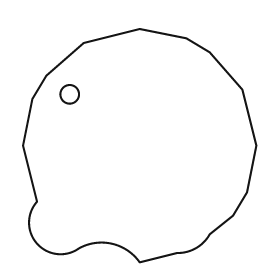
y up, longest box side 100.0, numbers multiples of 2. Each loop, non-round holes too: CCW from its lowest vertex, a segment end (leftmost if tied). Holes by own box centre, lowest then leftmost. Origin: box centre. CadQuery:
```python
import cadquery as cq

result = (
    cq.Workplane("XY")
    .moveTo(0.0, -50.0)
    .lineTo(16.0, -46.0)
    .threePointArc((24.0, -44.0), (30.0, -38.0))
    .lineTo(40.0, -30.0)
    .lineTo(46.0, -20.0)
    .lineTo(50.0, 0.0)
    .lineTo(44.0, 24.0)
    .lineTo(30.0, 40.0)
    .lineTo(20.0, 46.0)
    .lineTo(0.0, 50.0)
    .lineTo(-24.0, 44.0)
    .lineTo(-40.0, 30.0)
    .lineTo(-46.0, 20.0)
    .lineTo(-50.0, 0.0)
    .lineTo(-44.0, -24.0)
    .threePointArc((-44.0, -42.0), (-26.0, -44.0))
    .threePointArc((-12.0, -42.0), (0.0, -50.0))
    .close()
    .moveTo(-30.0, 22.0)
    .circle(4.0)
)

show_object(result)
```